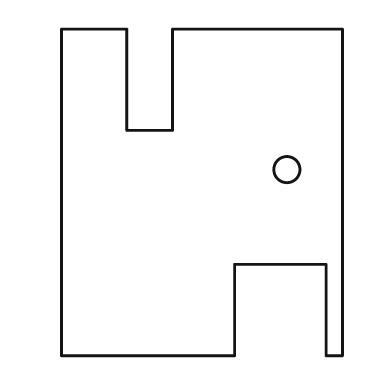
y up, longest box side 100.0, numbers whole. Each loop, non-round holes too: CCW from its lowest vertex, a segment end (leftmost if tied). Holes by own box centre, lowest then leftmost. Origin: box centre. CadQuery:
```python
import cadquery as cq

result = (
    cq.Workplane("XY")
    .moveTo(-43.0, -50.0)
    .lineTo(10.0, -50.0)
    .lineTo(10.0, -22.0)
    .lineTo(38.0, -22.0)
    .lineTo(38.0, -50.0)
    .lineTo(43.0, -50.0)
    .lineTo(43.0, 50.0)
    .lineTo(-9.0, 50.0)
    .lineTo(-9.0, 19.0)
    .lineTo(-23.0, 19.0)
    .lineTo(-23.0, 50.0)
    .lineTo(-43.0, 50.0)
    .close()
    .moveTo(26.0, 7.0)
    .circle(4.0)
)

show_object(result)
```